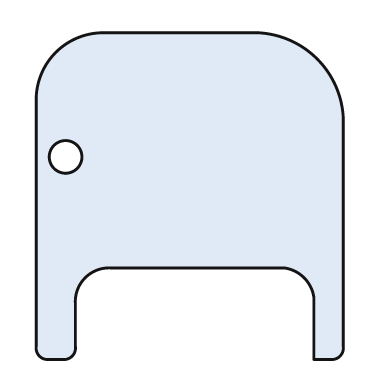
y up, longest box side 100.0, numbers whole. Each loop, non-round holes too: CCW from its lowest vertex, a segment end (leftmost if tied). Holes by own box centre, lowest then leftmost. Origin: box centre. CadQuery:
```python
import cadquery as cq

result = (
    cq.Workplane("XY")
    .moveTo(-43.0, -50.0)
    .lineTo(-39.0, -50.0)
    .threePointArc((-36.0, -49.0), (-35.0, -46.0))
    .lineTo(-35.0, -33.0)
    .threePointArc((-32.0, -25.0), (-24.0, -22.0))
    .lineTo(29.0, -22.0)
    .threePointArc((35.0, -25.0), (38.0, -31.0))
    .lineTo(38.0, -50.0)
    .lineTo(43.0, -50.0)
    .threePointArc((46.0, -49.0), (47.0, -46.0))
    .lineTo(47.0, 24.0)
    .threePointArc((39.0, 42.0), (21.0, 50.0))
    .lineTo(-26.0, 50.0)
    .threePointArc((-41.0, 44.0), (-47.0, 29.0))
    .lineTo(-47.0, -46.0)
    .threePointArc((-46.0, -49.0), (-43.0, -50.0))
    .close()
    .moveTo(-38.0, 12.0)
    .circle(5.0)
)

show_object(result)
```